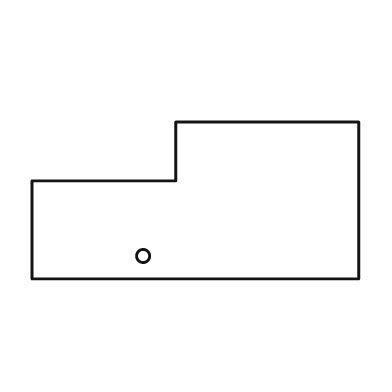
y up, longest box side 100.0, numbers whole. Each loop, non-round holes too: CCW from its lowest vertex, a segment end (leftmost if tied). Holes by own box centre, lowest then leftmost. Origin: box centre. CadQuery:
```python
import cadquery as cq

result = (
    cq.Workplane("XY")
    .moveTo(-50.0, -24.0)
    .lineTo(50.0, -24.0)
    .lineTo(50.0, 24.0)
    .lineTo(-6.0, 24.0)
    .lineTo(-6.0, 6.0)
    .lineTo(-50.0, 6.0)
    .close()
    .moveTo(-16.0, -17.0)
    .circle(2.0)
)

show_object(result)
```